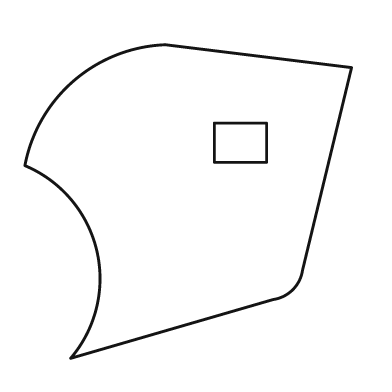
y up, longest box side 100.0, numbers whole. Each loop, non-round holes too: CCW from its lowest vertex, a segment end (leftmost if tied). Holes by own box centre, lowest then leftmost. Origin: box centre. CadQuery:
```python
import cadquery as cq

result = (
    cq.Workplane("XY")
    .moveTo(-36.0, -48.0)
    .lineTo(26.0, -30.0)
    .threePointArc((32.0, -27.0), (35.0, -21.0))
    .lineTo(50.0, 41.0)
    .lineTo(-7.0, 48.0)
    .threePointArc((-35.0, 37.0), (-50.0, 11.0))
    .threePointArc((-28.0, -15.0), (-36.0, -48.0))
    .close()
    .moveTo(8.0, 12.0)
    .lineTo(24.0, 12.0)
    .lineTo(24.0, 24.0)
    .lineTo(8.0, 24.0)
    .close()
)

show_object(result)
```